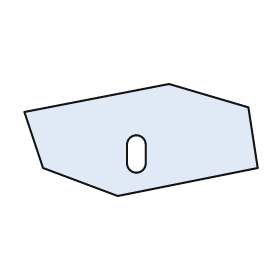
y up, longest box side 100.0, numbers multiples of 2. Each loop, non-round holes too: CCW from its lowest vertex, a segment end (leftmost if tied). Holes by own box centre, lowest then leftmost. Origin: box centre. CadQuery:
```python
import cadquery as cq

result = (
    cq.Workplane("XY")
    .moveTo(-10.0, -24.0)
    .lineTo(50.0, -12.0)
    .lineTo(46.0, 14.0)
    .lineTo(12.0, 24.0)
    .lineTo(-50.0, 12.0)
    .lineTo(-42.0, -12.0)
    .close()
    .moveTo(-6.0, -10.0)
    .threePointArc((-2.0, -14.0), (2.0, -10.0))
    .lineTo(2.0, -2.0)
    .threePointArc((-2.0, 2.0), (-6.0, -2.0))
    .close()
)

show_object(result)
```